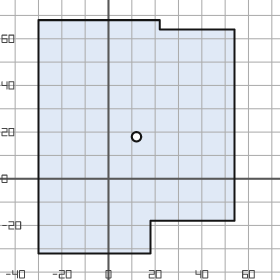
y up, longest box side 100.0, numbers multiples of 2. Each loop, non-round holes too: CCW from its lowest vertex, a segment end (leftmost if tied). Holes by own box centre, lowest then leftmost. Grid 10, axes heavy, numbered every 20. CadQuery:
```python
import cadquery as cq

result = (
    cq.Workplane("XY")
    .moveTo(-30.0, -32.0)
    .lineTo(18.0, -32.0)
    .lineTo(18.0, -18.0)
    .lineTo(54.0, -18.0)
    .lineTo(54.0, 64.0)
    .lineTo(22.0, 64.0)
    .lineTo(22.0, 68.0)
    .lineTo(-30.0, 68.0)
    .close()
    .moveTo(12.0, 18.0)
    .circle(2.0)
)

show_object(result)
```